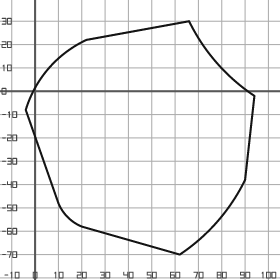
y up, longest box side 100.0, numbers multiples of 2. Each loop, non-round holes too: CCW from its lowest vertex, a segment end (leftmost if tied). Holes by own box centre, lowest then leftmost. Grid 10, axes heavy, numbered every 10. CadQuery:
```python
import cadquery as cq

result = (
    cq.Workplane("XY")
    .moveTo(62.0, -70.0)
    .threePointArc((78.0, -56.0), (90.0, -38.0))
    .lineTo(94.0, -2.0)
    .threePointArc((78.0, 12.0), (66.0, 30.0))
    .lineTo(22.0, 22.0)
    .threePointArc((6.0, 10.0), (-4.0, -8.0))
    .lineTo(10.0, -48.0)
    .threePointArc((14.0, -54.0), (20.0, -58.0))
    .close()
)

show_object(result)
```